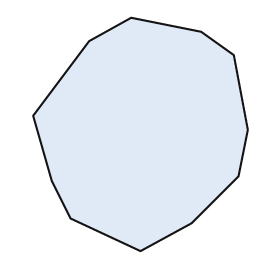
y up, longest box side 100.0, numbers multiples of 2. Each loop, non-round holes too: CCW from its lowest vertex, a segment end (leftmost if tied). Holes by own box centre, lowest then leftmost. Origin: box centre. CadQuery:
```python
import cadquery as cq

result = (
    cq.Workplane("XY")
    .moveTo(0.0, -50.0)
    .lineTo(22.0, -38.0)
    .lineTo(42.0, -18.0)
    .lineTo(46.0, 2.0)
    .lineTo(40.0, 34.0)
    .lineTo(26.0, 44.0)
    .lineTo(-4.0, 50.0)
    .lineTo(-22.0, 40.0)
    .lineTo(-46.0, 8.0)
    .lineTo(-38.0, -20.0)
    .lineTo(-30.0, -36.0)
    .close()
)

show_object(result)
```